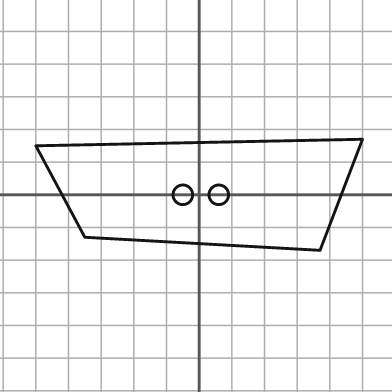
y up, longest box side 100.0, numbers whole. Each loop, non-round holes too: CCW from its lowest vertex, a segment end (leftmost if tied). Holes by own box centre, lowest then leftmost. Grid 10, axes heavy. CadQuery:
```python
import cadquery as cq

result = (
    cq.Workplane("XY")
    .moveTo(37.0, -17.0)
    .lineTo(50.0, 17.0)
    .lineTo(-50.0, 15.0)
    .lineTo(-35.0, -13.0)
    .close()
    .moveTo(-5.0, 0.0)
    .circle(3.0)
    .moveTo(6.0, 0.0)
    .circle(3.0)
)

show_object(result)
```